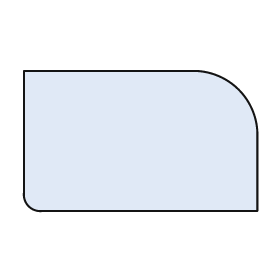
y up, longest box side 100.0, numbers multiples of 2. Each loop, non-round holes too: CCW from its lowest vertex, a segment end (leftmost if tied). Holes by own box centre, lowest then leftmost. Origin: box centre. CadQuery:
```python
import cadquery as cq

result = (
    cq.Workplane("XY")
    .moveTo(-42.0, -30.0)
    .lineTo(50.0, -30.0)
    .lineTo(50.0, 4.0)
    .threePointArc((42.0, 22.0), (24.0, 30.0))
    .lineTo(-50.0, 30.0)
    .lineTo(-50.0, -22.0)
    .threePointArc((-48.0, -28.0), (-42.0, -30.0))
    .close()
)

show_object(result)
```